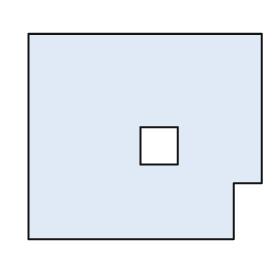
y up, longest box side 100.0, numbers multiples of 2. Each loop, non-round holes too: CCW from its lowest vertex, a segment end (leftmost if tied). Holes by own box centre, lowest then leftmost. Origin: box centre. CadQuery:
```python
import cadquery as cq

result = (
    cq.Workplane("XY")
    .moveTo(-50.0, -44.0)
    .lineTo(38.0, -44.0)
    .lineTo(38.0, -20.0)
    .lineTo(50.0, -20.0)
    .lineTo(50.0, 44.0)
    .lineTo(-50.0, 44.0)
    .close()
    .moveTo(-2.0, -12.0)
    .lineTo(14.0, -12.0)
    .lineTo(14.0, 4.0)
    .lineTo(-2.0, 4.0)
    .close()
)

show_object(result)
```